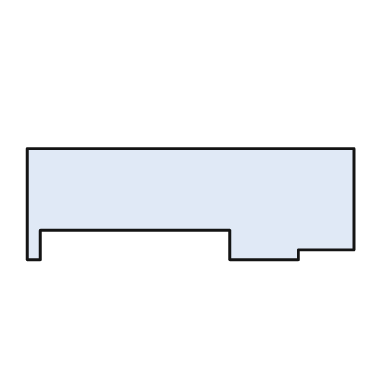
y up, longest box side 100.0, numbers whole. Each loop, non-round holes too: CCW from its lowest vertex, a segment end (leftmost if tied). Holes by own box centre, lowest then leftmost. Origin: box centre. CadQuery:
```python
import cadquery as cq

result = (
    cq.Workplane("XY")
    .moveTo(-50.0, -17.0)
    .lineTo(-46.0, -17.0)
    .lineTo(-46.0, -8.0)
    .lineTo(12.0, -8.0)
    .lineTo(12.0, -17.0)
    .lineTo(33.0, -17.0)
    .lineTo(33.0, -14.0)
    .lineTo(50.0, -14.0)
    .lineTo(50.0, 17.0)
    .lineTo(-50.0, 17.0)
    .close()
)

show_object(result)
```